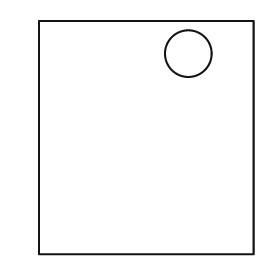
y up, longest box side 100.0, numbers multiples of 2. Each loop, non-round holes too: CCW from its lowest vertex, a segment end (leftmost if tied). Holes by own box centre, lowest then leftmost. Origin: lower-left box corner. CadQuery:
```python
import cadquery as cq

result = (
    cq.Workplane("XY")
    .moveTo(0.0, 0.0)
    .lineTo(92.0, 0.0)
    .lineTo(92.0, 100.0)
    .lineTo(0.0, 100.0)
    .close()
    .moveTo(64.0, 86.0)
    .circle(10.0)
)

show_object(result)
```